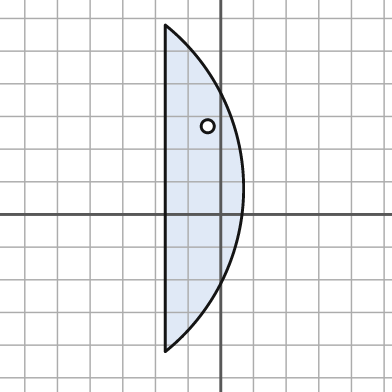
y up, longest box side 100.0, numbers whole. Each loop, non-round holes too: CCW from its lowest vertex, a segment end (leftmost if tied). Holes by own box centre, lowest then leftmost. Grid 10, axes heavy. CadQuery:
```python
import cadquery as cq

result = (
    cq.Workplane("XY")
    .moveTo(-17.0, -42.0)
    .threePointArc((7.0, 8.0), (-17.0, 58.0))
    .close()
    .moveTo(-4.0, 27.0)
    .circle(2.0)
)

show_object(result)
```